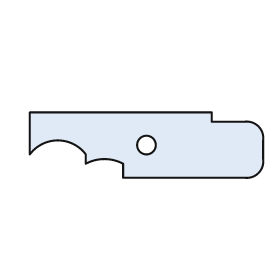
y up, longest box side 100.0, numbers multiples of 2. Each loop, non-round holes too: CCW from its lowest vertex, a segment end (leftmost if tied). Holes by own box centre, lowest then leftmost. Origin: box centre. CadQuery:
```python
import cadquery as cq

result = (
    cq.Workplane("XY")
    .moveTo(-10.0, -14.0)
    .lineTo(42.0, -14.0)
    .threePointArc((48.0, -12.0), (50.0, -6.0))
    .lineTo(50.0, 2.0)
    .threePointArc((48.0, 8.0), (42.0, 10.0))
    .lineTo(28.0, 10.0)
    .lineTo(28.0, 14.0)
    .lineTo(-50.0, 14.0)
    .lineTo(-50.0, -4.0)
    .threePointArc((-38.0, 2.0), (-26.0, -4.0))
    .lineTo(-26.0, -8.0)
    .threePointArc((-18.0, -6.0), (-10.0, -8.0))
    .close()
    .moveTo(0.0, 0.0)
    .circle(4.0)
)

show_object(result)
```